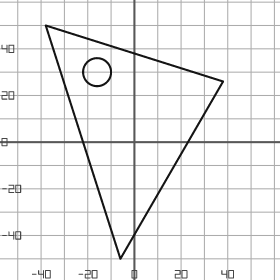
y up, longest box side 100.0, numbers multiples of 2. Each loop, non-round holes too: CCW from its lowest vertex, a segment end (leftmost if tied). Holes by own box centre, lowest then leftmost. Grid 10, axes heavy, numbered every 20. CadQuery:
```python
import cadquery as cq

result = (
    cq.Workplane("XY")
    .moveTo(-6.0, -50.0)
    .lineTo(38.0, 26.0)
    .lineTo(-38.0, 50.0)
    .close()
    .moveTo(-16.0, 30.0)
    .circle(6.0)
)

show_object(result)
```